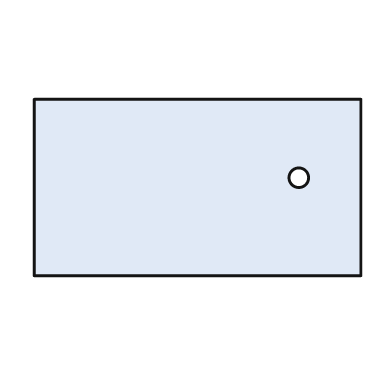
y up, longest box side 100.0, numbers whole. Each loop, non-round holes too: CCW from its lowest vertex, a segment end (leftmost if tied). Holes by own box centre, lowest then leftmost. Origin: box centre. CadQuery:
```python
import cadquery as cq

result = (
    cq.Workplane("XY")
    .moveTo(-50.0, -27.0)
    .lineTo(50.0, -27.0)
    .lineTo(50.0, 27.0)
    .lineTo(-50.0, 27.0)
    .close()
    .moveTo(31.0, 3.0)
    .circle(3.0)
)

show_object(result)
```